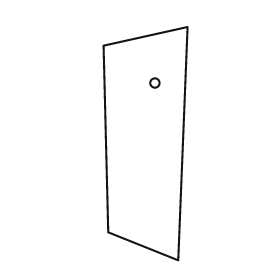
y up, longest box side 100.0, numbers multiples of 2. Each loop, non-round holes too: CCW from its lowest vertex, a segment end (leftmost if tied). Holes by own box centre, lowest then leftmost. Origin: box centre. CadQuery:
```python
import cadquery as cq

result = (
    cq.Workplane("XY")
    .moveTo(14.0, -50.0)
    .lineTo(18.0, 50.0)
    .lineTo(-18.0, 42.0)
    .lineTo(-16.0, -38.0)
    .close()
    .moveTo(4.0, 26.0)
    .circle(2.0)
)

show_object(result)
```